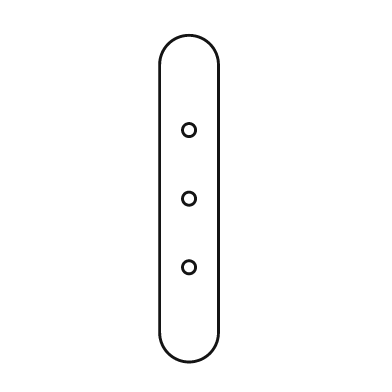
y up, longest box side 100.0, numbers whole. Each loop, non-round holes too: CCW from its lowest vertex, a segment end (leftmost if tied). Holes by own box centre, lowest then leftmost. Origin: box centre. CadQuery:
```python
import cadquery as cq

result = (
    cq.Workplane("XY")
    .moveTo(-9.0, -41.0)
    .threePointArc((0.0, -50.0), (9.0, -41.0))
    .lineTo(9.0, 41.0)
    .threePointArc((0.0, 50.0), (-9.0, 41.0))
    .close()
    .moveTo(0.0, -21.0)
    .circle(2.0)
    .moveTo(0.0, 0.0)
    .circle(2.0)
    .moveTo(0.0, 21.0)
    .circle(2.0)
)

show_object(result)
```